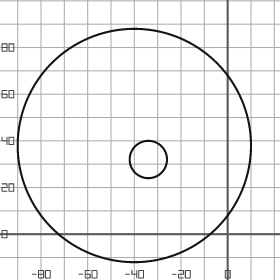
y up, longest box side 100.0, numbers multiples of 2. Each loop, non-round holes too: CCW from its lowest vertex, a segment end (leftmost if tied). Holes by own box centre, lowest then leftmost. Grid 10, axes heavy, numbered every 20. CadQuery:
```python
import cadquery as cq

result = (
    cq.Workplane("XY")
    .moveTo(-40.0, 38.0)
    .circle(50.0)
    .moveTo(-34.0, 32.0)
    .circle(8.0)
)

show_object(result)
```